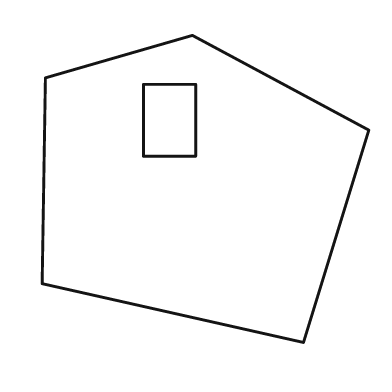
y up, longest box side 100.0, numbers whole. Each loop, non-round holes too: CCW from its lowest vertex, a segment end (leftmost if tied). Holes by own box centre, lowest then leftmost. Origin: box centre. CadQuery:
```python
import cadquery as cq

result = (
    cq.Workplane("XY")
    .moveTo(30.0, -47.0)
    .lineTo(50.0, 18.0)
    .lineTo(-4.0, 47.0)
    .lineTo(-49.0, 34.0)
    .lineTo(-50.0, -29.0)
    .close()
    .moveTo(-19.0, 10.0)
    .lineTo(-3.0, 10.0)
    .lineTo(-3.0, 32.0)
    .lineTo(-19.0, 32.0)
    .close()
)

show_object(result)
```